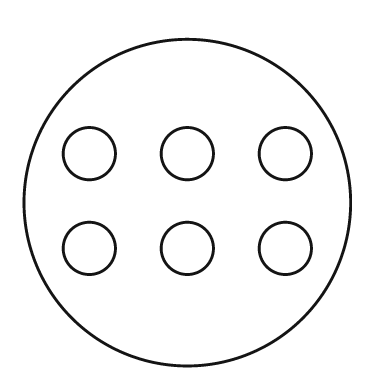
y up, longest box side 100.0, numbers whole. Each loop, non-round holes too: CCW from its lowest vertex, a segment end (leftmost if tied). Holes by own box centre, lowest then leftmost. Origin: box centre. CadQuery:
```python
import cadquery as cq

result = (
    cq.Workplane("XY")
    .moveTo(0.0, 0.0)
    .circle(50.0)
    .moveTo(-30.0, -14.0)
    .circle(8.0)
    .moveTo(0.0, -14.0)
    .circle(8.0)
    .moveTo(30.0, -14.0)
    .circle(8.0)
    .moveTo(-30.0, 15.0)
    .circle(8.0)
    .moveTo(0.0, 15.0)
    .circle(8.0)
    .moveTo(30.0, 15.0)
    .circle(8.0)
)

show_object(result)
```